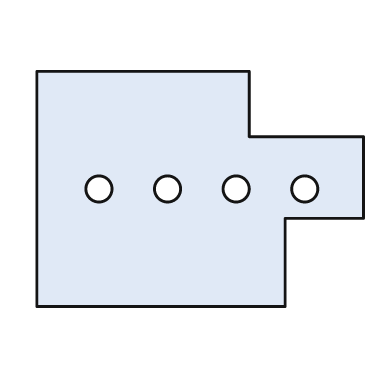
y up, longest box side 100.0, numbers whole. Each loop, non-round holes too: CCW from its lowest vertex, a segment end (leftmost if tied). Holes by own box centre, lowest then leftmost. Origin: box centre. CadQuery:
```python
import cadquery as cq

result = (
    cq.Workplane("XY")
    .moveTo(-50.0, -36.0)
    .lineTo(26.0, -36.0)
    .lineTo(26.0, -9.0)
    .lineTo(50.0, -9.0)
    .lineTo(50.0, 16.0)
    .lineTo(15.0, 16.0)
    .lineTo(15.0, 36.0)
    .lineTo(-50.0, 36.0)
    .close()
    .moveTo(-31.0, 0.0)
    .circle(4.0)
    .moveTo(-10.0, 0.0)
    .circle(4.0)
    .moveTo(11.0, 0.0)
    .circle(4.0)
    .moveTo(32.0, 0.0)
    .circle(4.0)
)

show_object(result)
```